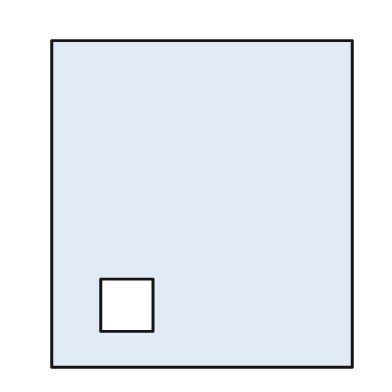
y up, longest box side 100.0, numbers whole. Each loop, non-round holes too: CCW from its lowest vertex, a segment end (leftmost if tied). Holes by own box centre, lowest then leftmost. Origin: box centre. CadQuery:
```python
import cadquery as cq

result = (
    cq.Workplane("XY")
    .moveTo(-46.0, -50.0)
    .lineTo(46.0, -50.0)
    .lineTo(46.0, 50.0)
    .lineTo(-46.0, 50.0)
    .close()
    .moveTo(-31.0, -39.0)
    .lineTo(-15.0, -39.0)
    .lineTo(-15.0, -23.0)
    .lineTo(-31.0, -23.0)
    .close()
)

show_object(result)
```